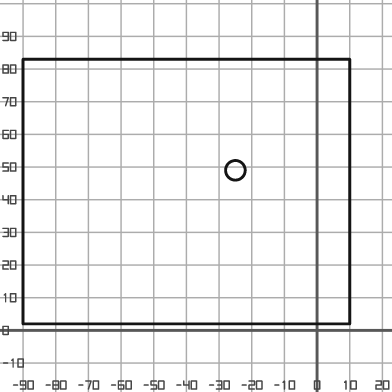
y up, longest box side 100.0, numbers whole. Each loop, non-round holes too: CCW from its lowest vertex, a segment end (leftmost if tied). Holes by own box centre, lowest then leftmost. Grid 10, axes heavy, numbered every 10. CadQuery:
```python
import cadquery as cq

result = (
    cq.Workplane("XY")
    .moveTo(-90.0, 2.0)
    .lineTo(10.0, 2.0)
    .lineTo(10.0, 83.0)
    .lineTo(-90.0, 83.0)
    .close()
    .moveTo(-25.0, 49.0)
    .circle(3.0)
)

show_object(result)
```